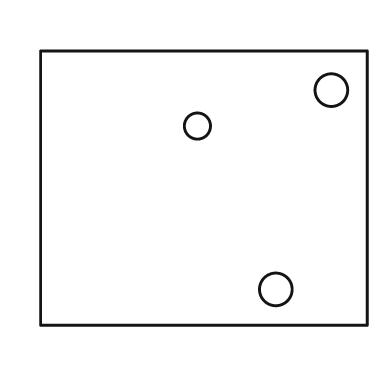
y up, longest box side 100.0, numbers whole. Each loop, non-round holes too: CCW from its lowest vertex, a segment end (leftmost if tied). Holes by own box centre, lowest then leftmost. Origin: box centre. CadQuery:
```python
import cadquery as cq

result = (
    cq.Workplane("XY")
    .moveTo(-50.0, -42.0)
    .lineTo(50.0, -42.0)
    .lineTo(50.0, 42.0)
    .lineTo(-50.0, 42.0)
    .close()
    .moveTo(22.0, -31.0)
    .circle(5.0)
    .moveTo(-2.0, 19.0)
    .circle(4.0)
    .moveTo(39.0, 30.0)
    .circle(5.0)
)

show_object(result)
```